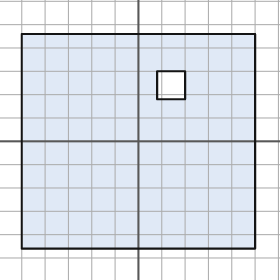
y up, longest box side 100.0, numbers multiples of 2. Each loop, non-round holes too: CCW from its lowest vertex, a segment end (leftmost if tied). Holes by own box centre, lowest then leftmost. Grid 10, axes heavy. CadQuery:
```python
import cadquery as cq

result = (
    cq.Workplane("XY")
    .moveTo(-50.0, -46.0)
    .lineTo(50.0, -46.0)
    .lineTo(50.0, 46.0)
    .lineTo(-50.0, 46.0)
    .close()
    .moveTo(8.0, 18.0)
    .lineTo(20.0, 18.0)
    .lineTo(20.0, 30.0)
    .lineTo(8.0, 30.0)
    .close()
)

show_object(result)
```